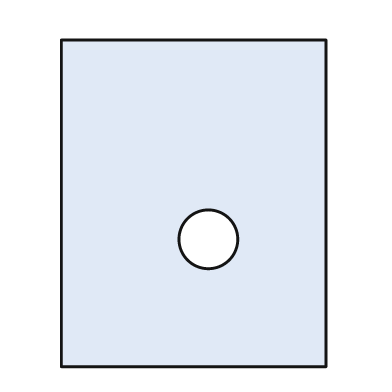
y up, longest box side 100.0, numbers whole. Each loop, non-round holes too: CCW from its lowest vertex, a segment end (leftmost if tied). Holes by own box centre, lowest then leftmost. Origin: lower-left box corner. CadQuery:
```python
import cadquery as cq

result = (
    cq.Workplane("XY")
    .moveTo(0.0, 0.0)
    .lineTo(81.0, 0.0)
    .lineTo(81.0, 100.0)
    .lineTo(0.0, 100.0)
    .close()
    .moveTo(45.0, 39.0)
    .circle(9.0)
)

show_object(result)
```